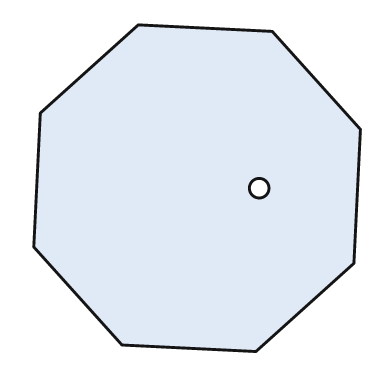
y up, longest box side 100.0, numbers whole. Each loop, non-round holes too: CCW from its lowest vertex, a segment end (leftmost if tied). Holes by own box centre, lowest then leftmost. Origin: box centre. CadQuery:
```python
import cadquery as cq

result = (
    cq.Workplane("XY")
    .moveTo(18.0, -50.0)
    .lineTo(48.0, -23.0)
    .lineTo(50.0, 18.0)
    .lineTo(23.0, 48.0)
    .lineTo(-18.0, 50.0)
    .lineTo(-48.0, 23.0)
    .lineTo(-50.0, -18.0)
    .lineTo(-23.0, -48.0)
    .close()
    .moveTo(19.0, 0.0)
    .circle(3.0)
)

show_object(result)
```